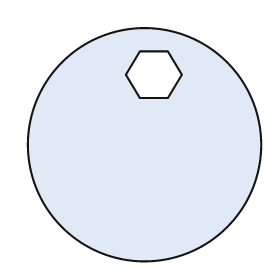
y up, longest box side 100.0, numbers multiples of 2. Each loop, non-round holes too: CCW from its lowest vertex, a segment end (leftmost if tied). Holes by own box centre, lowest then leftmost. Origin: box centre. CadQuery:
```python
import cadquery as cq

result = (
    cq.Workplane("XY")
    .moveTo(0.0, 0.0)
    .circle(50.0)
    .moveTo(-2.0, 20.0)
    .lineTo(10.0, 20.0)
    .lineTo(16.0, 30.0)
    .lineTo(10.0, 40.0)
    .lineTo(-2.0, 40.0)
    .lineTo(-8.0, 30.0)
    .close()
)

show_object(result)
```